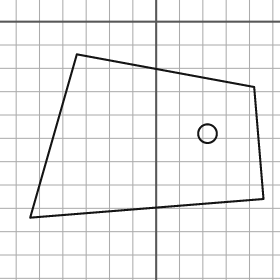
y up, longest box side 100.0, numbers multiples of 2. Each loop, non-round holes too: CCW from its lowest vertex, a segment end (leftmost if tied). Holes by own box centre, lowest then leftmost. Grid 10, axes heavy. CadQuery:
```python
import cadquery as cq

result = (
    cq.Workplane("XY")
    .moveTo(-54.0, -84.0)
    .lineTo(46.0, -76.0)
    .lineTo(42.0, -28.0)
    .lineTo(-34.0, -14.0)
    .close()
    .moveTo(22.0, -48.0)
    .circle(4.0)
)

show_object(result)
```